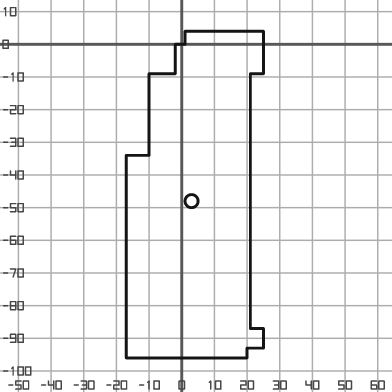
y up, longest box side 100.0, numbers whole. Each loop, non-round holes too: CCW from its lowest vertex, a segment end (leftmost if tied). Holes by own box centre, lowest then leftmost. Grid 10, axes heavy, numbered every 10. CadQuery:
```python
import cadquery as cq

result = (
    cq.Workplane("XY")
    .moveTo(-17.0, -96.0)
    .lineTo(20.0, -96.0)
    .lineTo(20.0, -93.0)
    .lineTo(25.0, -93.0)
    .lineTo(25.0, -87.0)
    .lineTo(21.0, -87.0)
    .lineTo(21.0, -9.0)
    .lineTo(25.0, -9.0)
    .lineTo(25.0, 4.0)
    .lineTo(1.0, 4.0)
    .lineTo(1.0, 0.0)
    .lineTo(-2.0, 0.0)
    .lineTo(-2.0, -9.0)
    .lineTo(-10.0, -9.0)
    .lineTo(-10.0, -34.0)
    .lineTo(-17.0, -34.0)
    .close()
    .moveTo(3.0, -48.0)
    .circle(2.0)
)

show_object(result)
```